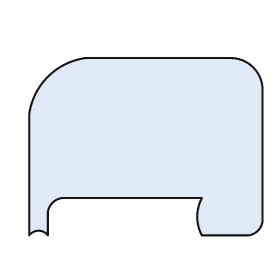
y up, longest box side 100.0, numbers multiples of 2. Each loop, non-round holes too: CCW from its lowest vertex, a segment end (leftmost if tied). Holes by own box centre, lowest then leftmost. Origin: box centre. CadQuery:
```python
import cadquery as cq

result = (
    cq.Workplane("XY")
    .moveTo(-50.0, -38.0)
    .threePointArc((-46.0, -36.0), (-42.0, -38.0))
    .lineTo(-42.0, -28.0)
    .threePointArc((-40.0, -24.0), (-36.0, -22.0))
    .lineTo(24.0, -22.0)
    .threePointArc((22.0, -30.0), (24.0, -38.0))
    .lineTo(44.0, -38.0)
    .threePointArc((48.0, -36.0), (50.0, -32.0))
    .lineTo(50.0, 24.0)
    .threePointArc((46.0, 34.0), (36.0, 38.0))
    .lineTo(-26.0, 38.0)
    .threePointArc((-42.0, 30.0), (-50.0, 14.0))
    .close()
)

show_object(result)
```